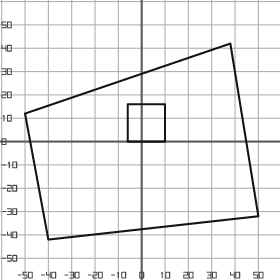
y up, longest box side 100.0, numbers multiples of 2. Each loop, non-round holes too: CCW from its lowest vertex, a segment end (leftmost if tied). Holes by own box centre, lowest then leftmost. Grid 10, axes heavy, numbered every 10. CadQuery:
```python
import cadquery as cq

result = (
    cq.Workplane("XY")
    .moveTo(-40.0, -42.0)
    .lineTo(50.0, -32.0)
    .lineTo(38.0, 42.0)
    .lineTo(-50.0, 12.0)
    .close()
    .moveTo(-6.0, 0.0)
    .lineTo(10.0, 0.0)
    .lineTo(10.0, 16.0)
    .lineTo(-6.0, 16.0)
    .close()
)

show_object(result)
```